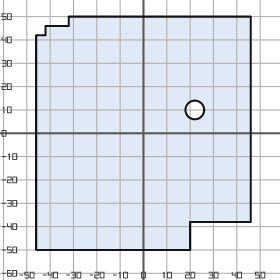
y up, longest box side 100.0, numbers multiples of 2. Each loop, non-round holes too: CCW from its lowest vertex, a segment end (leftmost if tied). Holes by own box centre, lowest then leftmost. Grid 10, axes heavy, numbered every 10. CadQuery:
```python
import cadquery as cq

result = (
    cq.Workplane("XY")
    .moveTo(-46.0, -50.0)
    .lineTo(20.0, -50.0)
    .lineTo(20.0, -38.0)
    .lineTo(46.0, -38.0)
    .lineTo(46.0, 50.0)
    .lineTo(-32.0, 50.0)
    .lineTo(-32.0, 46.0)
    .lineTo(-42.0, 46.0)
    .lineTo(-42.0, 42.0)
    .lineTo(-46.0, 42.0)
    .close()
    .moveTo(22.0, 10.0)
    .circle(4.0)
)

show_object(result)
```